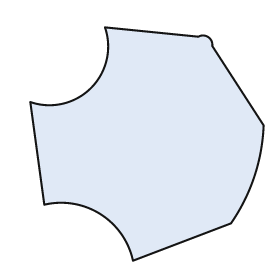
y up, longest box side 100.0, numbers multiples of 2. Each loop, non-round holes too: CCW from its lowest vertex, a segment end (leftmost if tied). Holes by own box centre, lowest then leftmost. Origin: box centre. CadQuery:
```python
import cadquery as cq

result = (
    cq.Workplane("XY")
    .moveTo(-6.0, -50.0)
    .lineTo(36.0, -34.0)
    .threePointArc((46.0, -14.0), (50.0, 8.0))
    .lineTo(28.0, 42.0)
    .threePointArc((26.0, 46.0), (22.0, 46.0))
    .lineTo(-18.0, 50.0)
    .threePointArc((-24.0, 24.0), (-50.0, 18.0))
    .lineTo(-44.0, -26.0)
    .threePointArc((-20.0, -30.0), (-6.0, -50.0))
    .close()
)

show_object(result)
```